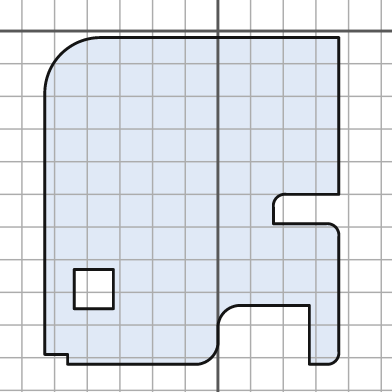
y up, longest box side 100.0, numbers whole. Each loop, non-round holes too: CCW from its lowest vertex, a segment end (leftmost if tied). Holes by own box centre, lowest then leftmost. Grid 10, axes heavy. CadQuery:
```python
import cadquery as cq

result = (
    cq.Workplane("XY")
    .moveTo(-46.0, -102.0)
    .lineTo(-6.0, -102.0)
    .threePointArc((-2.0, -100.0), (0.0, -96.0))
    .lineTo(0.0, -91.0)
    .threePointArc((2.0, -86.0), (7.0, -84.0))
    .lineTo(28.0, -84.0)
    .lineTo(28.0, -102.0)
    .lineTo(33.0, -102.0)
    .threePointArc((36.0, -101.0), (37.0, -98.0))
    .lineTo(37.0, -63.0)
    .threePointArc((36.0, -60.0), (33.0, -59.0))
    .lineTo(17.0, -59.0)
    .lineTo(17.0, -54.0)
    .threePointArc((18.0, -51.0), (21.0, -50.0))
    .lineTo(37.0, -50.0)
    .lineTo(37.0, -2.0)
    .lineTo(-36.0, -2.0)
    .threePointArc((-48.0, -7.0), (-53.0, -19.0))
    .lineTo(-53.0, -99.0)
    .lineTo(-46.0, -99.0)
    .close()
    .moveTo(-44.0, -85.0)
    .lineTo(-32.0, -85.0)
    .lineTo(-32.0, -73.0)
    .lineTo(-44.0, -73.0)
    .close()
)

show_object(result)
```